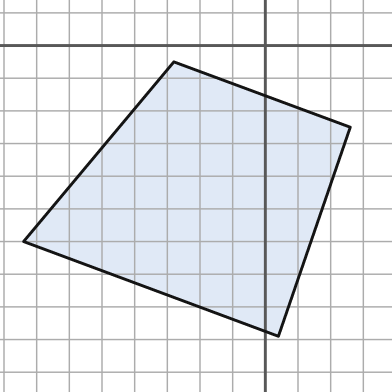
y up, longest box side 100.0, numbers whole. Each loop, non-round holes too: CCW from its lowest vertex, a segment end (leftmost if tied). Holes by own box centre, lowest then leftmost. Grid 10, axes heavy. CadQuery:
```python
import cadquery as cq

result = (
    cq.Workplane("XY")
    .moveTo(4.0, -89.0)
    .lineTo(26.0, -25.0)
    .lineTo(-28.0, -5.0)
    .lineTo(-74.0, -60.0)
    .close()
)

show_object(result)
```